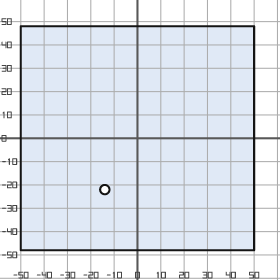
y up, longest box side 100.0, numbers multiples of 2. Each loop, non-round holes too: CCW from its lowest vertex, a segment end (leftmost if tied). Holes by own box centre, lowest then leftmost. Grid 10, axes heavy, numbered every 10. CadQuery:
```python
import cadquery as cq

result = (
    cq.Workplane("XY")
    .moveTo(-50.0, -48.0)
    .lineTo(50.0, -48.0)
    .lineTo(50.0, 48.0)
    .lineTo(-50.0, 48.0)
    .close()
    .moveTo(-14.0, -22.0)
    .circle(2.0)
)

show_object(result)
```